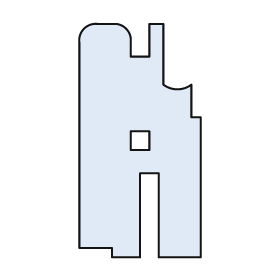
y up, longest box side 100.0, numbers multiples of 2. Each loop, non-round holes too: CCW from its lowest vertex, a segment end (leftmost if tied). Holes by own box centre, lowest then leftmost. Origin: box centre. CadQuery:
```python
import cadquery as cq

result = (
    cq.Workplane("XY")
    .moveTo(-12.0, -50.0)
    .lineTo(0.0, -50.0)
    .lineTo(0.0, -14.0)
    .lineTo(8.0, -14.0)
    .lineTo(8.0, -50.0)
    .lineTo(26.0, -50.0)
    .lineTo(26.0, 10.0)
    .lineTo(22.0, 10.0)
    .lineTo(22.0, 24.0)
    .threePointArc((16.0, 22.0), (10.0, 24.0))
    .lineTo(10.0, 50.0)
    .lineTo(4.0, 50.0)
    .lineTo(4.0, 36.0)
    .lineTo(-4.0, 36.0)
    .lineTo(-4.0, 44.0)
    .threePointArc((-6.0, 48.0), (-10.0, 50.0))
    .lineTo(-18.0, 50.0)
    .threePointArc((-24.0, 48.0), (-26.0, 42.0))
    .lineTo(-26.0, -46.0)
    .lineTo(-12.0, -46.0)
    .close()
    .moveTo(-4.0, -4.0)
    .lineTo(4.0, -4.0)
    .lineTo(4.0, 4.0)
    .lineTo(-4.0, 4.0)
    .close()
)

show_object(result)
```